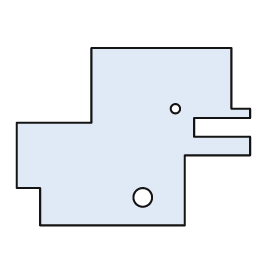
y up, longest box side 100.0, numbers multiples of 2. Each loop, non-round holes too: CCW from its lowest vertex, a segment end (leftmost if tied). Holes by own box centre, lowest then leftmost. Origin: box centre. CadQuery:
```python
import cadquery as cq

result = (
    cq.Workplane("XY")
    .moveTo(-40.0, -38.0)
    .lineTo(22.0, -38.0)
    .lineTo(22.0, -8.0)
    .lineTo(50.0, -8.0)
    .lineTo(50.0, 0.0)
    .lineTo(26.0, 0.0)
    .lineTo(26.0, 8.0)
    .lineTo(50.0, 8.0)
    .lineTo(50.0, 12.0)
    .lineTo(42.0, 12.0)
    .lineTo(42.0, 38.0)
    .lineTo(-18.0, 38.0)
    .lineTo(-18.0, 6.0)
    .lineTo(-50.0, 6.0)
    .lineTo(-50.0, -22.0)
    .lineTo(-40.0, -22.0)
    .close()
    .moveTo(4.0, -26.0)
    .circle(4.0)
    .moveTo(18.0, 12.0)
    .circle(2.0)
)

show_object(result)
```